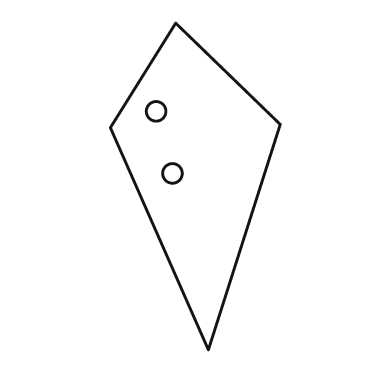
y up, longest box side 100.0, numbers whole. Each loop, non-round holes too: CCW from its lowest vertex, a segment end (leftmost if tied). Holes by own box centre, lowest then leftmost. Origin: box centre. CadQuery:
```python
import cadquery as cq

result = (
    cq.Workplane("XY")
    .moveTo(4.0, -50.0)
    .lineTo(26.0, 19.0)
    .lineTo(-6.0, 50.0)
    .lineTo(-26.0, 18.0)
    .close()
    .moveTo(-7.0, 4.0)
    .circle(3.0)
    .moveTo(-12.0, 23.0)
    .circle(3.0)
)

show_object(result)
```